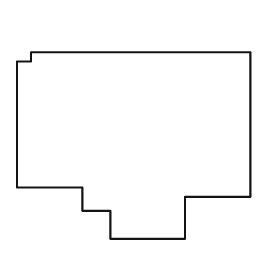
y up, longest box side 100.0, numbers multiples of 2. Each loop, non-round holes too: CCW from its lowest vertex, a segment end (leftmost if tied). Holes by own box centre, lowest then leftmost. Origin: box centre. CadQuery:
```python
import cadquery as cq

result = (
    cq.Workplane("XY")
    .moveTo(-10.0, -40.0)
    .lineTo(22.0, -40.0)
    .lineTo(22.0, -22.0)
    .lineTo(50.0, -22.0)
    .lineTo(50.0, 40.0)
    .lineTo(-44.0, 40.0)
    .lineTo(-44.0, 36.0)
    .lineTo(-50.0, 36.0)
    .lineTo(-50.0, -18.0)
    .lineTo(-22.0, -18.0)
    .lineTo(-22.0, -28.0)
    .lineTo(-10.0, -28.0)
    .close()
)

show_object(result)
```